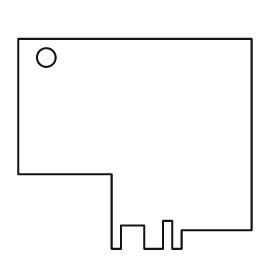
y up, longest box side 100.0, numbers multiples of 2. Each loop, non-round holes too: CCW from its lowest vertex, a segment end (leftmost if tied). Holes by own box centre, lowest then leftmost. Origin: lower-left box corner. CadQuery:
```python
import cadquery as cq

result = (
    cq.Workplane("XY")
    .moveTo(40.0, 0.0)
    .lineTo(44.0, 0.0)
    .lineTo(44.0, 10.0)
    .lineTo(54.0, 10.0)
    .lineTo(54.0, 0.0)
    .lineTo(62.0, 0.0)
    .lineTo(62.0, 12.0)
    .lineTo(66.0, 12.0)
    .lineTo(66.0, 0.0)
    .lineTo(70.0, 0.0)
    .lineTo(70.0, 8.0)
    .lineTo(100.0, 8.0)
    .lineTo(100.0, 90.0)
    .lineTo(0.0, 90.0)
    .lineTo(0.0, 32.0)
    .lineTo(40.0, 32.0)
    .close()
    .moveTo(12.0, 82.0)
    .circle(4.0)
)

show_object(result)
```